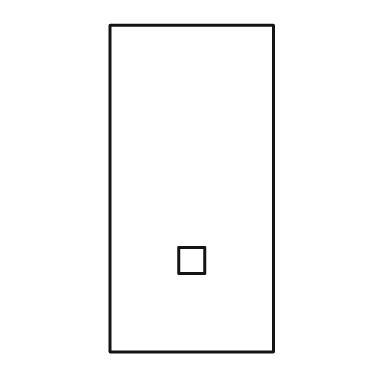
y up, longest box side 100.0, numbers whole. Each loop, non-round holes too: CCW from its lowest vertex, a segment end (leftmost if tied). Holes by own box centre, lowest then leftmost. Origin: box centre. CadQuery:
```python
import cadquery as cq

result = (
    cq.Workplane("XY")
    .moveTo(-25.0, -50.0)
    .lineTo(25.0, -50.0)
    .lineTo(25.0, 50.0)
    .lineTo(-25.0, 50.0)
    .close()
    .moveTo(-4.0, -26.0)
    .lineTo(4.0, -26.0)
    .lineTo(4.0, -18.0)
    .lineTo(-4.0, -18.0)
    .close()
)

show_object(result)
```